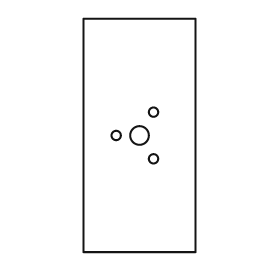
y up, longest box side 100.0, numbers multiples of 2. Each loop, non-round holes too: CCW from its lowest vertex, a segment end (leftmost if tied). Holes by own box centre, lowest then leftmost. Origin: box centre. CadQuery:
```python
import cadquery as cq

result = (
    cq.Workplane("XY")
    .moveTo(-24.0, -50.0)
    .lineTo(24.0, -50.0)
    .lineTo(24.0, 50.0)
    .lineTo(-24.0, 50.0)
    .close()
    .moveTo(6.0, -10.0)
    .circle(2.0)
    .moveTo(-10.0, 0.0)
    .circle(2.0)
    .moveTo(0.0, 0.0)
    .circle(4.0)
    .moveTo(6.0, 10.0)
    .circle(2.0)
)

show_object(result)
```